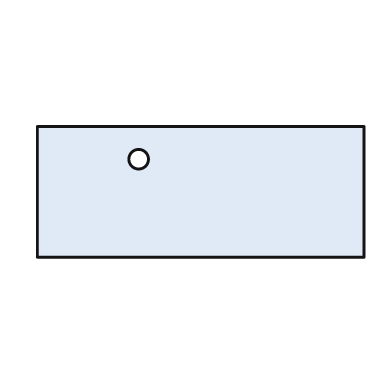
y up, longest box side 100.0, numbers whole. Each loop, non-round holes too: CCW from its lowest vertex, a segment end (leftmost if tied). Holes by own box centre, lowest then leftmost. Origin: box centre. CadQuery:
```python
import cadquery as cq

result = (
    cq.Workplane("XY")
    .moveTo(-50.0, -20.0)
    .lineTo(50.0, -20.0)
    .lineTo(50.0, 20.0)
    .lineTo(-50.0, 20.0)
    .close()
    .moveTo(-19.0, 10.0)
    .circle(3.0)
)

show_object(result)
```